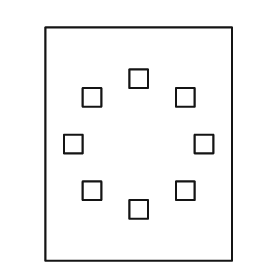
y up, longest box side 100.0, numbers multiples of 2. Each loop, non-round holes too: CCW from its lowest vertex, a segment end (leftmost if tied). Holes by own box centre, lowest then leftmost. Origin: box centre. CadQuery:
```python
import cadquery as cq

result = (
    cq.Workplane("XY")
    .moveTo(-40.0, -50.0)
    .lineTo(40.0, -50.0)
    .lineTo(40.0, 50.0)
    .lineTo(-40.0, 50.0)
    .close()
    .moveTo(-4.0, -32.0)
    .lineTo(4.0, -32.0)
    .lineTo(4.0, -24.0)
    .lineTo(-4.0, -24.0)
    .close()
    .moveTo(-24.0, -24.0)
    .lineTo(-16.0, -24.0)
    .lineTo(-16.0, -16.0)
    .lineTo(-24.0, -16.0)
    .close()
    .moveTo(16.0, -24.0)
    .lineTo(24.0, -24.0)
    .lineTo(24.0, -16.0)
    .lineTo(16.0, -16.0)
    .close()
    .moveTo(-32.0, -4.0)
    .lineTo(-24.0, -4.0)
    .lineTo(-24.0, 4.0)
    .lineTo(-32.0, 4.0)
    .close()
    .moveTo(24.0, -4.0)
    .lineTo(32.0, -4.0)
    .lineTo(32.0, 4.0)
    .lineTo(24.0, 4.0)
    .close()
    .moveTo(-24.0, 16.0)
    .lineTo(-16.0, 16.0)
    .lineTo(-16.0, 24.0)
    .lineTo(-24.0, 24.0)
    .close()
    .moveTo(16.0, 16.0)
    .lineTo(24.0, 16.0)
    .lineTo(24.0, 24.0)
    .lineTo(16.0, 24.0)
    .close()
    .moveTo(-4.0, 24.0)
    .lineTo(4.0, 24.0)
    .lineTo(4.0, 32.0)
    .lineTo(-4.0, 32.0)
    .close()
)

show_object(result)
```